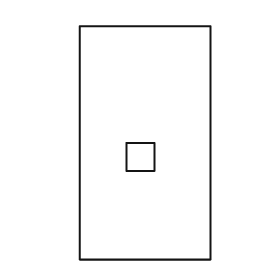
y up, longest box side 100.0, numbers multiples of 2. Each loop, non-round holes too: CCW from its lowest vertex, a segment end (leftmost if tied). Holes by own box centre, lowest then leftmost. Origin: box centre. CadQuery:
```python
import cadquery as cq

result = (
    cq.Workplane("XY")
    .moveTo(-28.0, -50.0)
    .lineTo(28.0, -50.0)
    .lineTo(28.0, 50.0)
    .lineTo(-28.0, 50.0)
    .close()
    .moveTo(-8.0, -12.0)
    .lineTo(4.0, -12.0)
    .lineTo(4.0, 0.0)
    .lineTo(-8.0, 0.0)
    .close()
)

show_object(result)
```